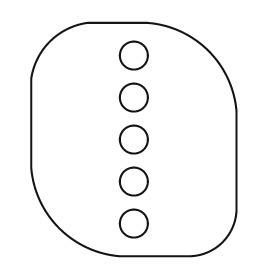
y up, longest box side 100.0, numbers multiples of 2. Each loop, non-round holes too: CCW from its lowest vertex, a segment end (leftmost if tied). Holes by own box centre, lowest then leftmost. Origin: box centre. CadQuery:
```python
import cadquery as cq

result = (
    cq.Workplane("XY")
    .moveTo(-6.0, -50.0)
    .lineTo(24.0, -50.0)
    .threePointArc((38.0, -44.0), (44.0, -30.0))
    .lineTo(44.0, 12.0)
    .threePointArc((32.0, 38.0), (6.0, 50.0))
    .lineTo(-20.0, 50.0)
    .threePointArc((-36.0, 42.0), (-44.0, 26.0))
    .lineTo(-44.0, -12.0)
    .threePointArc((-32.0, -38.0), (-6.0, -50.0))
    .close()
    .moveTo(0.0, -36.0)
    .circle(6.0)
    .moveTo(0.0, -18.0)
    .circle(6.0)
    .moveTo(0.0, 0.0)
    .circle(6.0)
    .moveTo(0.0, 18.0)
    .circle(6.0)
    .moveTo(0.0, 36.0)
    .circle(6.0)
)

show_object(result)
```